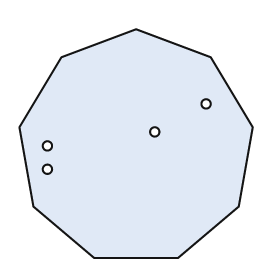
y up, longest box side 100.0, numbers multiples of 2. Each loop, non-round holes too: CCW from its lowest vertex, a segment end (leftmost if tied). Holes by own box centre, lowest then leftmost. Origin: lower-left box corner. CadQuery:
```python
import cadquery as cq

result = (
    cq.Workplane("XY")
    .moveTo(32.0, 0.0)
    .lineTo(68.0, 0.0)
    .lineTo(94.0, 22.0)
    .lineTo(100.0, 56.0)
    .lineTo(82.0, 86.0)
    .lineTo(50.0, 98.0)
    .lineTo(18.0, 86.0)
    .lineTo(0.0, 56.0)
    .lineTo(6.0, 22.0)
    .close()
    .moveTo(12.0, 38.0)
    .circle(2.0)
    .moveTo(12.0, 48.0)
    .circle(2.0)
    .moveTo(58.0, 54.0)
    .circle(2.0)
    .moveTo(80.0, 66.0)
    .circle(2.0)
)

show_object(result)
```